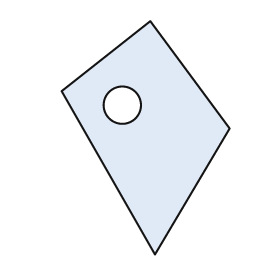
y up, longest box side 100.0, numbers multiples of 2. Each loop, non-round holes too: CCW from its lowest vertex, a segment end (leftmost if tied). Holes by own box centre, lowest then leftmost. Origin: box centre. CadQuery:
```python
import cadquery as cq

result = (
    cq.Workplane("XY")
    .moveTo(4.0, -50.0)
    .lineTo(36.0, 4.0)
    .lineTo(2.0, 50.0)
    .lineTo(-36.0, 20.0)
    .close()
    .moveTo(-10.0, 14.0)
    .circle(8.0)
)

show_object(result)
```